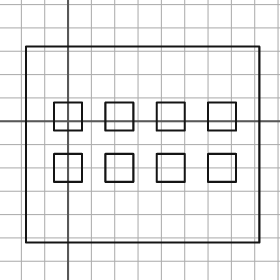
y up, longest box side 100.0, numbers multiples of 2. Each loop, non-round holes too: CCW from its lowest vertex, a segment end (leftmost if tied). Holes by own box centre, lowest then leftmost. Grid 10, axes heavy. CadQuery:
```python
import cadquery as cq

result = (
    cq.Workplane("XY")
    .moveTo(-18.0, -52.0)
    .lineTo(82.0, -52.0)
    .lineTo(82.0, 32.0)
    .lineTo(-18.0, 32.0)
    .close()
    .moveTo(-6.0, -26.0)
    .lineTo(6.0, -26.0)
    .lineTo(6.0, -14.0)
    .lineTo(-6.0, -14.0)
    .close()
    .moveTo(16.0, -26.0)
    .lineTo(28.0, -26.0)
    .lineTo(28.0, -14.0)
    .lineTo(16.0, -14.0)
    .close()
    .moveTo(38.0, -26.0)
    .lineTo(50.0, -26.0)
    .lineTo(50.0, -14.0)
    .lineTo(38.0, -14.0)
    .close()
    .moveTo(60.0, -26.0)
    .lineTo(72.0, -26.0)
    .lineTo(72.0, -14.0)
    .lineTo(60.0, -14.0)
    .close()
    .moveTo(-6.0, -4.0)
    .lineTo(6.0, -4.0)
    .lineTo(6.0, 8.0)
    .lineTo(-6.0, 8.0)
    .close()
    .moveTo(16.0, -4.0)
    .lineTo(28.0, -4.0)
    .lineTo(28.0, 8.0)
    .lineTo(16.0, 8.0)
    .close()
    .moveTo(38.0, -4.0)
    .lineTo(50.0, -4.0)
    .lineTo(50.0, 8.0)
    .lineTo(38.0, 8.0)
    .close()
    .moveTo(60.0, -4.0)
    .lineTo(72.0, -4.0)
    .lineTo(72.0, 8.0)
    .lineTo(60.0, 8.0)
    .close()
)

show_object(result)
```